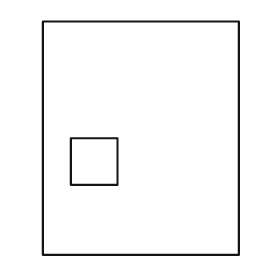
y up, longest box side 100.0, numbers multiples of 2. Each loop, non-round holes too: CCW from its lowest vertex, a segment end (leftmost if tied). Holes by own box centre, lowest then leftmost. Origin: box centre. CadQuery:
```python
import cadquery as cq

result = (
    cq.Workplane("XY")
    .moveTo(-42.0, -50.0)
    .lineTo(42.0, -50.0)
    .lineTo(42.0, 50.0)
    .lineTo(-42.0, 50.0)
    .close()
    .moveTo(-30.0, -20.0)
    .lineTo(-10.0, -20.0)
    .lineTo(-10.0, 0.0)
    .lineTo(-30.0, 0.0)
    .close()
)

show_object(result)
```